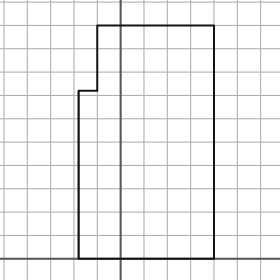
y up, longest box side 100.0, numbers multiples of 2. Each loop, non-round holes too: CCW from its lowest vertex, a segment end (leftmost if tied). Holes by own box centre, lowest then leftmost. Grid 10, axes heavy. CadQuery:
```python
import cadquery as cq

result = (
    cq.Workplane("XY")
    .moveTo(-18.0, 0.0)
    .lineTo(40.0, 0.0)
    .lineTo(40.0, 100.0)
    .lineTo(-10.0, 100.0)
    .lineTo(-10.0, 72.0)
    .lineTo(-18.0, 72.0)
    .close()
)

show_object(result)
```